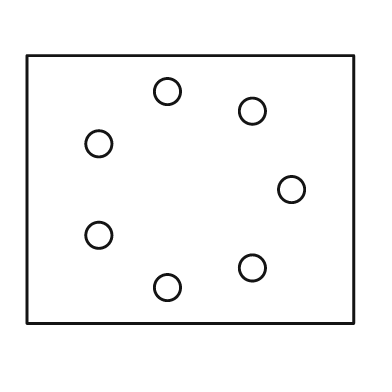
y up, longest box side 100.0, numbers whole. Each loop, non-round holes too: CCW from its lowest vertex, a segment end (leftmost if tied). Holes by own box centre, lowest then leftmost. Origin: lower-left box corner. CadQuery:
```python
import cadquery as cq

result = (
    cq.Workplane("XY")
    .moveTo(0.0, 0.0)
    .lineTo(100.0, 0.0)
    .lineTo(100.0, 82.0)
    .lineTo(0.0, 82.0)
    .close()
    .moveTo(43.0, 11.0)
    .circle(4.0)
    .moveTo(69.0, 17.0)
    .circle(4.0)
    .moveTo(22.0, 27.0)
    .circle(4.0)
    .moveTo(81.0, 41.0)
    .circle(4.0)
    .moveTo(22.0, 55.0)
    .circle(4.0)
    .moveTo(69.0, 65.0)
    .circle(4.0)
    .moveTo(43.0, 71.0)
    .circle(4.0)
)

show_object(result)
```